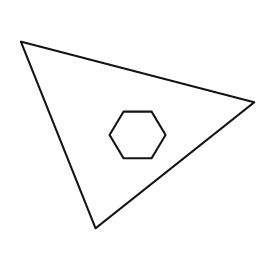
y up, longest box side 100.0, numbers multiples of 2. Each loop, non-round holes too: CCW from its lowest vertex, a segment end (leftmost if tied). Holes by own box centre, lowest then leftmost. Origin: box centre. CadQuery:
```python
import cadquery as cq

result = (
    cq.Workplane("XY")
    .moveTo(-18.0, -40.0)
    .lineTo(50.0, 14.0)
    .lineTo(-50.0, 40.0)
    .close()
    .moveTo(-6.0, -10.0)
    .lineTo(6.0, -10.0)
    .lineTo(12.0, 0.0)
    .lineTo(6.0, 10.0)
    .lineTo(-6.0, 10.0)
    .lineTo(-12.0, 0.0)
    .close()
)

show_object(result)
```